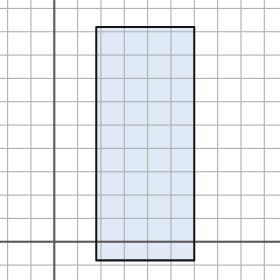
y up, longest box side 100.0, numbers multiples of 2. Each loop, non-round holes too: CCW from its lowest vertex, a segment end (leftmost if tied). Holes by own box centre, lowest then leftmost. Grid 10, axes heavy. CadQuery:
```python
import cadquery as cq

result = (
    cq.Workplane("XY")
    .moveTo(18.0, -8.0)
    .lineTo(60.0, -8.0)
    .lineTo(60.0, 92.0)
    .lineTo(18.0, 92.0)
    .close()
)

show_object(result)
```